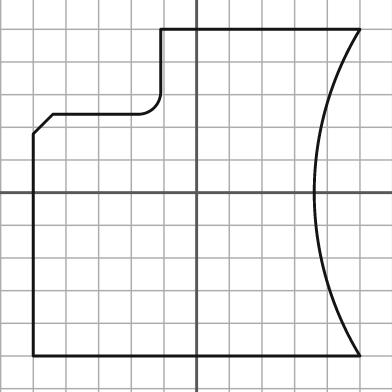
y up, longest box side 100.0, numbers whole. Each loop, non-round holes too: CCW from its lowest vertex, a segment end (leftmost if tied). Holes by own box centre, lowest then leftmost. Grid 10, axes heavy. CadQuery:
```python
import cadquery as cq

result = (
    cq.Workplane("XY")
    .moveTo(-50.0, -50.0)
    .lineTo(50.0, -50.0)
    .threePointArc((36.0, 0.0), (50.0, 50.0))
    .lineTo(-11.0, 50.0)
    .lineTo(-11.0, 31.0)
    .threePointArc((-13.0, 26.0), (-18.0, 24.0))
    .lineTo(-44.0, 24.0)
    .lineTo(-50.0, 18.0)
    .close()
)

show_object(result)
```